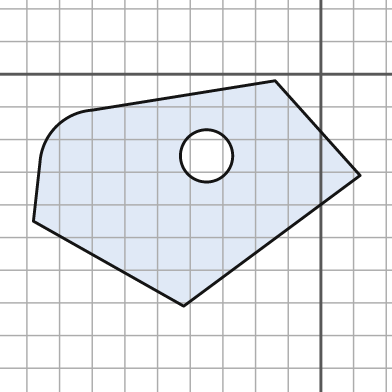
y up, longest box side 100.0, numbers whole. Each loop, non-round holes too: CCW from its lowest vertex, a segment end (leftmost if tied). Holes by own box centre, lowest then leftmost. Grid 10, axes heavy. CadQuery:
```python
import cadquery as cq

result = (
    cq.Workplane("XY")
    .moveTo(-42.0, -71.0)
    .lineTo(12.0, -31.0)
    .lineTo(-14.0, -2.0)
    .lineTo(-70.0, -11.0)
    .threePointArc((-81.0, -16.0), (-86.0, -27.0))
    .lineTo(-88.0, -45.0)
    .close()
    .moveTo(-35.0, -25.0)
    .circle(8.0)
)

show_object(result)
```